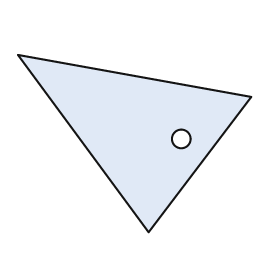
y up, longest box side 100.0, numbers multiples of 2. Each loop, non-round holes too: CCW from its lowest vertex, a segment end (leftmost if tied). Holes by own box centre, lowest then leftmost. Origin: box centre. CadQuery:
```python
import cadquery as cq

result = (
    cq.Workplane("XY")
    .moveTo(6.0, -38.0)
    .lineTo(50.0, 20.0)
    .lineTo(-50.0, 38.0)
    .close()
    .moveTo(20.0, 2.0)
    .circle(4.0)
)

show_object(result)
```